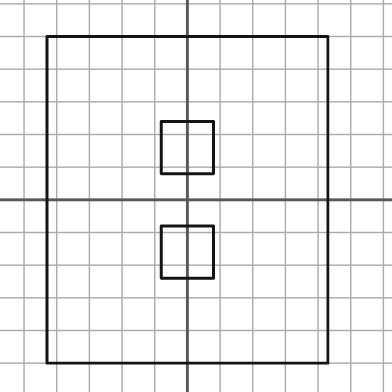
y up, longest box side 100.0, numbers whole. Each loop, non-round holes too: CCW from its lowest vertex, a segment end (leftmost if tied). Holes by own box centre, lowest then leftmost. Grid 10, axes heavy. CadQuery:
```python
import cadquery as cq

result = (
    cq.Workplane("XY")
    .moveTo(-43.0, -50.0)
    .lineTo(43.0, -50.0)
    .lineTo(43.0, 50.0)
    .lineTo(-43.0, 50.0)
    .close()
    .moveTo(-8.0, -24.0)
    .lineTo(8.0, -24.0)
    .lineTo(8.0, -8.0)
    .lineTo(-8.0, -8.0)
    .close()
    .moveTo(-8.0, 8.0)
    .lineTo(8.0, 8.0)
    .lineTo(8.0, 24.0)
    .lineTo(-8.0, 24.0)
    .close()
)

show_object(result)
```